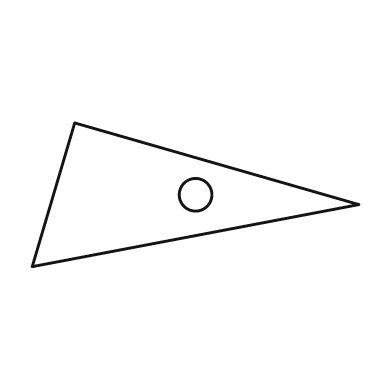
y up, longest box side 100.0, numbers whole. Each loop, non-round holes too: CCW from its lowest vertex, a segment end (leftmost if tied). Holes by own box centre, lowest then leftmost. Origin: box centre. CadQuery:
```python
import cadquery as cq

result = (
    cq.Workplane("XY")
    .moveTo(-50.0, -22.0)
    .lineTo(50.0, -3.0)
    .lineTo(-37.0, 22.0)
    .close()
    .moveTo(0.0, 0.0)
    .circle(5.0)
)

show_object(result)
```